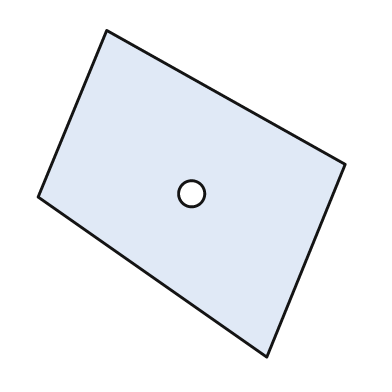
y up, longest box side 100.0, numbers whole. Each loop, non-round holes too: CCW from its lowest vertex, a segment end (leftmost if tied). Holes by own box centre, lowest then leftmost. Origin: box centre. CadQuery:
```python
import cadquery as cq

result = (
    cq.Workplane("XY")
    .moveTo(23.0, -50.0)
    .lineTo(47.0, 9.0)
    .lineTo(-26.0, 50.0)
    .lineTo(-47.0, -1.0)
    .close()
    .moveTo(0.0, 0.0)
    .circle(4.0)
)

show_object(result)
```